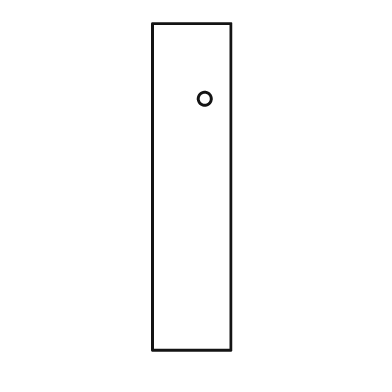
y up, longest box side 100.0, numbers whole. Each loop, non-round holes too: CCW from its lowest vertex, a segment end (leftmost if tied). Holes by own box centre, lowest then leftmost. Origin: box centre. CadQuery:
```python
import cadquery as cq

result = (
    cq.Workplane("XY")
    .moveTo(-12.0, -50.0)
    .lineTo(12.0, -50.0)
    .lineTo(12.0, 50.0)
    .lineTo(-12.0, 50.0)
    .close()
    .moveTo(4.0, 27.0)
    .circle(2.0)
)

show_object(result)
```